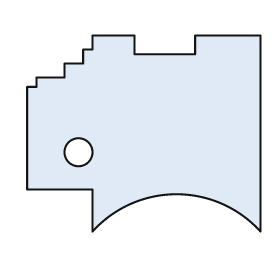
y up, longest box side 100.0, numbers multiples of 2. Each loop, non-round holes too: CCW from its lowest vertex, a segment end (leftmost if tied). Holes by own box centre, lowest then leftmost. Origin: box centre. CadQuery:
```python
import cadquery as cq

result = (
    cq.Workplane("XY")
    .moveTo(-22.0, -42.0)
    .threePointArc((14.0, -26.0), (50.0, -42.0))
    .lineTo(50.0, 42.0)
    .lineTo(22.0, 42.0)
    .lineTo(22.0, 34.0)
    .lineTo(-4.0, 34.0)
    .lineTo(-4.0, 42.0)
    .lineTo(-22.0, 42.0)
    .lineTo(-22.0, 36.0)
    .lineTo(-26.0, 36.0)
    .lineTo(-26.0, 30.0)
    .lineTo(-34.0, 30.0)
    .lineTo(-34.0, 24.0)
    .lineTo(-46.0, 24.0)
    .lineTo(-46.0, 20.0)
    .lineTo(-50.0, 20.0)
    .lineTo(-50.0, -24.0)
    .lineTo(-22.0, -24.0)
    .close()
    .moveTo(-28.0, -8.0)
    .circle(6.0)
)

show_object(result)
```